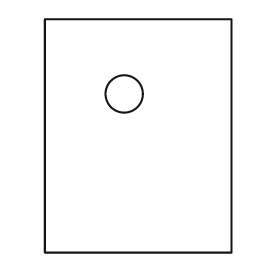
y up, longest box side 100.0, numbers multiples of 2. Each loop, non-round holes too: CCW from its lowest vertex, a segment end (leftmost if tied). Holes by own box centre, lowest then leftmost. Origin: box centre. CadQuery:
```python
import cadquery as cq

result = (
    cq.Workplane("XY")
    .moveTo(-40.0, -50.0)
    .lineTo(40.0, -50.0)
    .lineTo(40.0, 50.0)
    .lineTo(-40.0, 50.0)
    .close()
    .moveTo(-6.0, 18.0)
    .circle(8.0)
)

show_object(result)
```